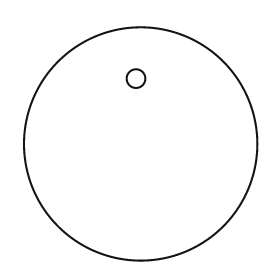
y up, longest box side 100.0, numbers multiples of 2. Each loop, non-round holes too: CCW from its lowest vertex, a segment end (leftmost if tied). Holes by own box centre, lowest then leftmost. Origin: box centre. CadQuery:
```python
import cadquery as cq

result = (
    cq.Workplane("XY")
    .moveTo(0.0, 0.0)
    .circle(50.0)
    .moveTo(-2.0, 28.0)
    .circle(4.0)
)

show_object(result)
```